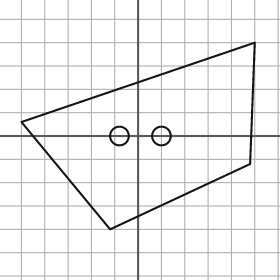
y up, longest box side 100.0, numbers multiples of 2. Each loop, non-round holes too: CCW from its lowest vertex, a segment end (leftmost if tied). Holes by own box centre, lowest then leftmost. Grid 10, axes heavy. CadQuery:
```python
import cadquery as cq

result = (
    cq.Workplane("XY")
    .moveTo(-12.0, -40.0)
    .lineTo(48.0, -12.0)
    .lineTo(50.0, 40.0)
    .lineTo(-50.0, 6.0)
    .close()
    .moveTo(-8.0, 0.0)
    .circle(4.0)
    .moveTo(10.0, 0.0)
    .circle(4.0)
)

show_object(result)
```